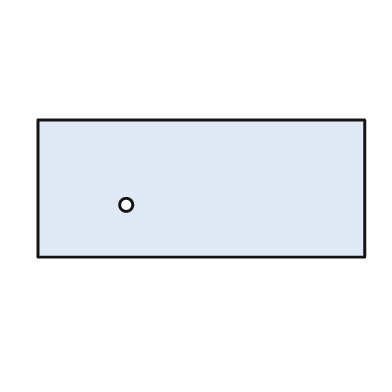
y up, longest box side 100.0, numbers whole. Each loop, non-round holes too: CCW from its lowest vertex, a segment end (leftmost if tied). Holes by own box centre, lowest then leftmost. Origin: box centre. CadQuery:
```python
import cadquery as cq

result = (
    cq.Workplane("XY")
    .moveTo(-50.0, -21.0)
    .lineTo(50.0, -21.0)
    .lineTo(50.0, 21.0)
    .lineTo(-50.0, 21.0)
    .close()
    .moveTo(-23.0, -5.0)
    .circle(2.0)
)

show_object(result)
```